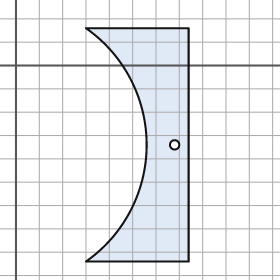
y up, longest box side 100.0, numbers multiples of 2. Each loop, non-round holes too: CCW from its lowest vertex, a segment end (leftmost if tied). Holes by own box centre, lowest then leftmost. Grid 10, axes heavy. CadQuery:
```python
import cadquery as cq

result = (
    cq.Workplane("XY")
    .moveTo(30.0, -84.0)
    .lineTo(74.0, -84.0)
    .lineTo(74.0, 16.0)
    .lineTo(30.0, 16.0)
    .threePointArc((56.0, -34.0), (30.0, -84.0))
    .close()
    .moveTo(68.0, -34.0)
    .circle(2.0)
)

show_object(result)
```